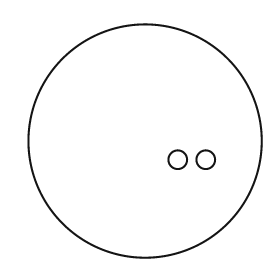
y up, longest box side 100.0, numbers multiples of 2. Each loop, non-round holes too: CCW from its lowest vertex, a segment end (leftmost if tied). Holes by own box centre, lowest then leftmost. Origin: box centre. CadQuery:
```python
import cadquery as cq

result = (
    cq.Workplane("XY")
    .moveTo(0.0, 0.0)
    .circle(50.0)
    .moveTo(14.0, -8.0)
    .circle(4.0)
    .moveTo(26.0, -8.0)
    .circle(4.0)
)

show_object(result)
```